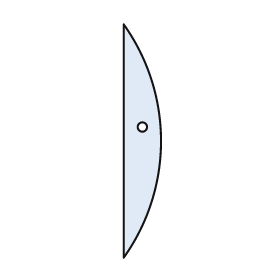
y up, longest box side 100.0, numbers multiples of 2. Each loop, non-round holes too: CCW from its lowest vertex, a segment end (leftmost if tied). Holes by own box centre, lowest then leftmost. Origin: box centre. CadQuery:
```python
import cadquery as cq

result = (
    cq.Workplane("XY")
    .moveTo(-8.0, -50.0)
    .threePointArc((8.0, 0.0), (-8.0, 50.0))
    .close()
    .moveTo(0.0, 6.0)
    .circle(2.0)
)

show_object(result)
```